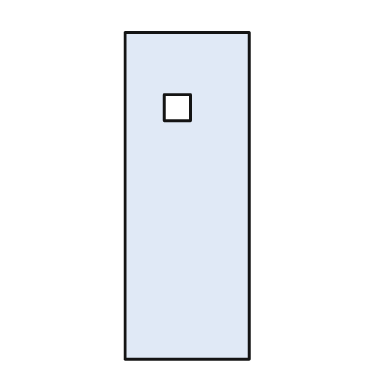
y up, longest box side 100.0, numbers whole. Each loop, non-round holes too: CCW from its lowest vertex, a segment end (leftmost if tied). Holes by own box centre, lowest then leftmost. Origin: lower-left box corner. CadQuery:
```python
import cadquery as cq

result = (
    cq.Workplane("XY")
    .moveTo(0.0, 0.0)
    .lineTo(38.0, 0.0)
    .lineTo(38.0, 100.0)
    .lineTo(0.0, 100.0)
    .close()
    .moveTo(12.0, 73.0)
    .lineTo(20.0, 73.0)
    .lineTo(20.0, 81.0)
    .lineTo(12.0, 81.0)
    .close()
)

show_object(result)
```